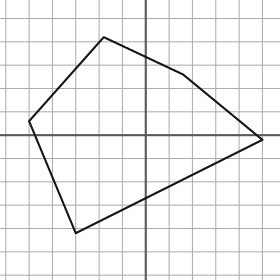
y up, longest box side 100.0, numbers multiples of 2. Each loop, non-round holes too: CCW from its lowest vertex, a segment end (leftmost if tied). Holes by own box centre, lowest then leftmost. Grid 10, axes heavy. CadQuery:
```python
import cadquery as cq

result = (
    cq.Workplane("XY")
    .moveTo(-30.0, -42.0)
    .lineTo(50.0, -2.0)
    .lineTo(16.0, 26.0)
    .lineTo(-18.0, 42.0)
    .lineTo(-50.0, 6.0)
    .close()
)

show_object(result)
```